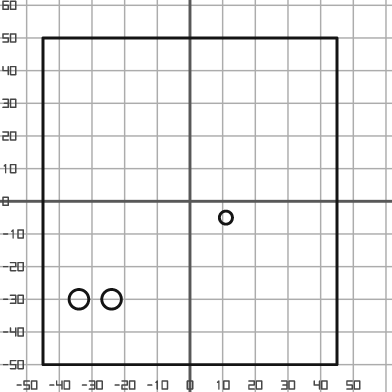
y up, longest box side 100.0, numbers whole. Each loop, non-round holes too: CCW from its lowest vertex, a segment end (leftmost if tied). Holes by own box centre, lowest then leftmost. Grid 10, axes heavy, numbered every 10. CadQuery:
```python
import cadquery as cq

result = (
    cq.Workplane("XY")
    .moveTo(-45.0, -50.0)
    .lineTo(45.0, -50.0)
    .lineTo(45.0, 50.0)
    .lineTo(-45.0, 50.0)
    .close()
    .moveTo(-34.0, -30.0)
    .circle(3.0)
    .moveTo(-24.0, -30.0)
    .circle(3.0)
    .moveTo(11.0, -5.0)
    .circle(2.0)
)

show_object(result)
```